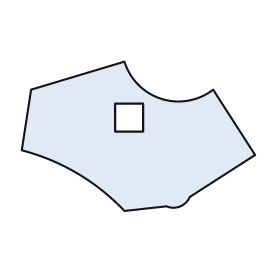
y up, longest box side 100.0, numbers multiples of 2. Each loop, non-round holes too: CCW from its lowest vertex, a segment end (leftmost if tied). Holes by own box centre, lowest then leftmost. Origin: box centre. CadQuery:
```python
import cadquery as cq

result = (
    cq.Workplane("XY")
    .moveTo(-6.0, -32.0)
    .lineTo(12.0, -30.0)
    .threePointArc((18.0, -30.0), (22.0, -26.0))
    .lineTo(50.0, -8.0)
    .lineTo(32.0, 20.0)
    .threePointArc((10.0, 16.0), (-6.0, 32.0))
    .lineTo(-46.0, 20.0)
    .lineTo(-50.0, -6.0)
    .threePointArc((-26.0, -16.0), (-6.0, -32.0))
    .close()
    .moveTo(-10.0, 2.0)
    .lineTo(2.0, 2.0)
    .lineTo(2.0, 14.0)
    .lineTo(-10.0, 14.0)
    .close()
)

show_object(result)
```